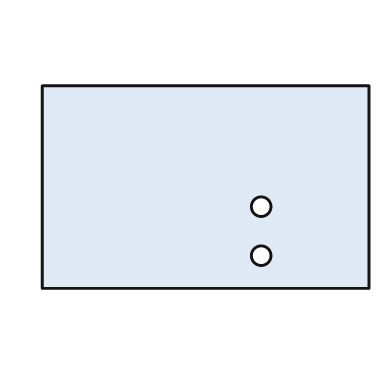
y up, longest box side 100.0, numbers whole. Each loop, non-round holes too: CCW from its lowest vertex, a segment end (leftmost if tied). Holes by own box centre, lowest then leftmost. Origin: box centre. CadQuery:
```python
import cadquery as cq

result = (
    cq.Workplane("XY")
    .moveTo(-50.0, -31.0)
    .lineTo(50.0, -31.0)
    .lineTo(50.0, 31.0)
    .lineTo(-50.0, 31.0)
    .close()
    .moveTo(17.0, -21.0)
    .circle(3.0)
    .moveTo(17.0, -6.0)
    .circle(3.0)
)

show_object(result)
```